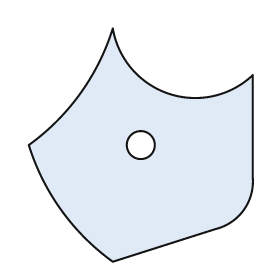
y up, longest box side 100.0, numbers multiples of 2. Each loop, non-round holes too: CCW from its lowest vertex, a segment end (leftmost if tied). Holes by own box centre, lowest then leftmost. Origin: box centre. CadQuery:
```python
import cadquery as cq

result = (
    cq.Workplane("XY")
    .moveTo(-12.0, -50.0)
    .lineTo(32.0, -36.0)
    .threePointArc((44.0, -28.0), (48.0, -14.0))
    .lineTo(48.0, 30.0)
    .threePointArc((12.0, 22.0), (-12.0, 50.0))
    .threePointArc((-26.0, 22.0), (-48.0, 0.0))
    .threePointArc((-34.0, -28.0), (-12.0, -50.0))
    .close()
    .moveTo(0.0, 0.0)
    .circle(6.0)
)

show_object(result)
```